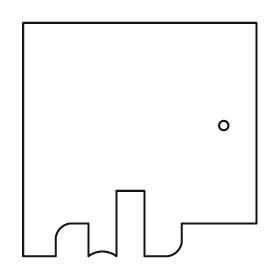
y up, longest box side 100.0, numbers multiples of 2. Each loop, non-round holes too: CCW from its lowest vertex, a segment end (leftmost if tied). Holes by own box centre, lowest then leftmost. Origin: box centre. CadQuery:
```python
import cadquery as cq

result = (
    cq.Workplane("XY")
    .moveTo(-50.0, -50.0)
    .lineTo(-36.0, -50.0)
    .lineTo(-36.0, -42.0)
    .threePointArc((-34.0, -38.0), (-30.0, -36.0))
    .lineTo(-22.0, -36.0)
    .lineTo(-22.0, -50.0)
    .threePointArc((-16.0, -48.0), (-10.0, -50.0))
    .lineTo(-10.0, -22.0)
    .lineTo(2.0, -22.0)
    .lineTo(2.0, -50.0)
    .lineTo(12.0, -50.0)
    .threePointArc((16.0, -48.0), (18.0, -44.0))
    .lineTo(18.0, -36.0)
    .lineTo(50.0, -36.0)
    .lineTo(50.0, 50.0)
    .lineTo(-50.0, 50.0)
    .close()
    .moveTo(36.0, 6.0)
    .circle(2.0)
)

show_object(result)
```